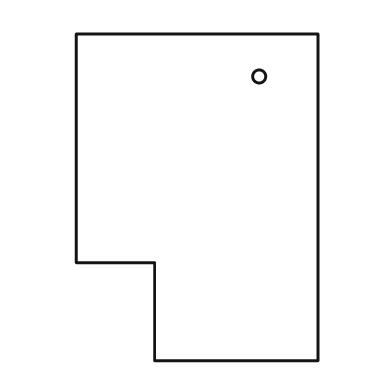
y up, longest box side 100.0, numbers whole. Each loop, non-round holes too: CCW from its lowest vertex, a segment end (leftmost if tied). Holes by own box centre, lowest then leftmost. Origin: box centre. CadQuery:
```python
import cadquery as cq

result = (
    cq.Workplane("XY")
    .moveTo(-13.0, -50.0)
    .lineTo(37.0, -50.0)
    .lineTo(37.0, 50.0)
    .lineTo(-37.0, 50.0)
    .lineTo(-37.0, -20.0)
    .lineTo(-13.0, -20.0)
    .close()
    .moveTo(19.0, 37.0)
    .circle(2.0)
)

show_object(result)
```